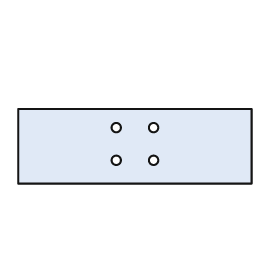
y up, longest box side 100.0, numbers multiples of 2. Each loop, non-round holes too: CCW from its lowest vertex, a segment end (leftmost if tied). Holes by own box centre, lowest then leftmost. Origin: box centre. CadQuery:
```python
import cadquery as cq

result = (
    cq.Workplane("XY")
    .moveTo(-50.0, -16.0)
    .lineTo(50.0, -16.0)
    .lineTo(50.0, 16.0)
    .lineTo(-50.0, 16.0)
    .close()
    .moveTo(-8.0, -6.0)
    .circle(2.0)
    .moveTo(8.0, -6.0)
    .circle(2.0)
    .moveTo(-8.0, 8.0)
    .circle(2.0)
    .moveTo(8.0, 8.0)
    .circle(2.0)
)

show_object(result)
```